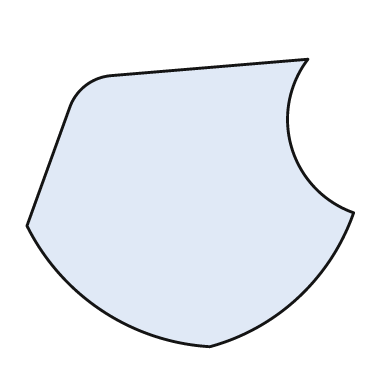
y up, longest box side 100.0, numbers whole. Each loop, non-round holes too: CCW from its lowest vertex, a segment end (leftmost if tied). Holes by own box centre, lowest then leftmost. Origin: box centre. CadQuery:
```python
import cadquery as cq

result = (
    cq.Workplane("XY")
    .moveTo(6.0, -44.0)
    .threePointArc((33.0, -29.0), (50.0, -3.0))
    .threePointArc((31.0, 17.0), (36.0, 44.0))
    .lineTo(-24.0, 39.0)
    .threePointArc((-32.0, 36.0), (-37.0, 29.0))
    .lineTo(-50.0, -7.0)
    .threePointArc((-27.0, -33.0), (6.0, -44.0))
    .close()
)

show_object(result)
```